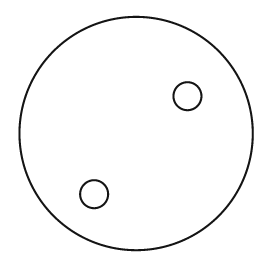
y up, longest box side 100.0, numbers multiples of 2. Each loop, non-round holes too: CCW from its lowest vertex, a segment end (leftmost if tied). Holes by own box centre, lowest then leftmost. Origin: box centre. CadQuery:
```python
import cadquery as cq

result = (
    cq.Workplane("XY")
    .moveTo(0.0, 0.0)
    .circle(50.0)
    .moveTo(-18.0, -26.0)
    .circle(6.0)
    .moveTo(22.0, 16.0)
    .circle(6.0)
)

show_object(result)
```